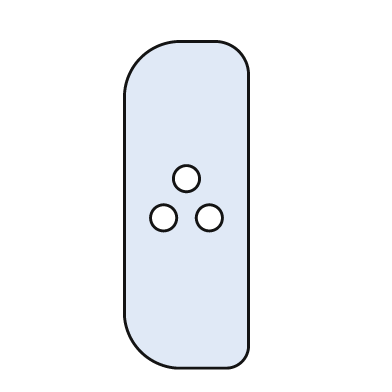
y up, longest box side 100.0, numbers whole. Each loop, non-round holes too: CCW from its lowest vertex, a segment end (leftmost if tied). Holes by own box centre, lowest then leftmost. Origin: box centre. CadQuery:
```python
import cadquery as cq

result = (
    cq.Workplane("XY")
    .moveTo(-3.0, -50.0)
    .lineTo(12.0, -50.0)
    .threePointArc((17.0, -48.0), (19.0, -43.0))
    .lineTo(19.0, 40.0)
    .threePointArc((16.0, 47.0), (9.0, 50.0))
    .lineTo(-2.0, 50.0)
    .threePointArc((-14.0, 45.0), (-19.0, 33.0))
    .lineTo(-19.0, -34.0)
    .threePointArc((-14.0, -45.0), (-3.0, -50.0))
    .close()
    .moveTo(-7.0, -4.0)
    .circle(4.0)
    .moveTo(7.0, -4.0)
    .circle(4.0)
    .moveTo(0.0, 8.0)
    .circle(4.0)
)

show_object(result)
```